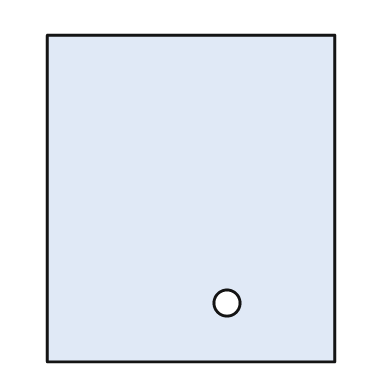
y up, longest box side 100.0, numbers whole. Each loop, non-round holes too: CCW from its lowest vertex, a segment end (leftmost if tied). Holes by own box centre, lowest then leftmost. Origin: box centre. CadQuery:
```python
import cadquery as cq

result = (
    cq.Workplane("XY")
    .moveTo(-44.0, -50.0)
    .lineTo(44.0, -50.0)
    .lineTo(44.0, 50.0)
    .lineTo(-44.0, 50.0)
    .close()
    .moveTo(11.0, -32.0)
    .circle(4.0)
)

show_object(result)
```